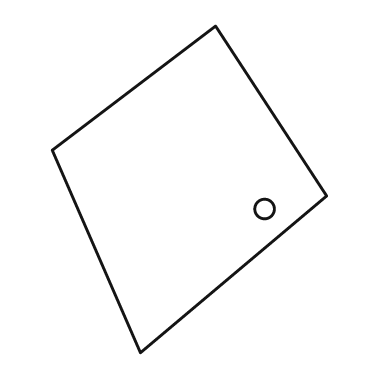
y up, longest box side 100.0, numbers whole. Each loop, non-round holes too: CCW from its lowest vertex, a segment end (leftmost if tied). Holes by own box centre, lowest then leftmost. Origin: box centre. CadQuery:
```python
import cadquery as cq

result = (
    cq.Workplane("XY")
    .moveTo(-15.0, -50.0)
    .lineTo(42.0, -2.0)
    .lineTo(8.0, 50.0)
    .lineTo(-42.0, 12.0)
    .close()
    .moveTo(23.0, -6.0)
    .circle(3.0)
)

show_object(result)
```